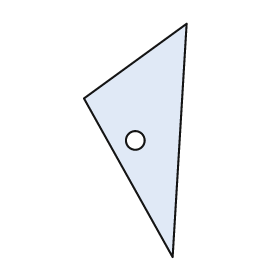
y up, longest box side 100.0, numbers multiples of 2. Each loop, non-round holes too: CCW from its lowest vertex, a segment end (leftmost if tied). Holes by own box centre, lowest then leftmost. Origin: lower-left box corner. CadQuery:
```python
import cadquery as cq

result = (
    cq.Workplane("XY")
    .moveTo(38.0, 0.0)
    .lineTo(44.0, 100.0)
    .lineTo(0.0, 68.0)
    .close()
    .moveTo(22.0, 50.0)
    .circle(4.0)
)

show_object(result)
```